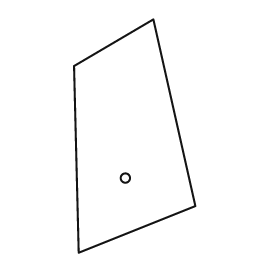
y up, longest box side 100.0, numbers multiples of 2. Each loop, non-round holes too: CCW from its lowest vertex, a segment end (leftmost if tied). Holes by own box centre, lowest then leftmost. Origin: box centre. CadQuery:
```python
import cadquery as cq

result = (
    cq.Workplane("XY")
    .moveTo(-24.0, -50.0)
    .lineTo(26.0, -30.0)
    .lineTo(8.0, 50.0)
    .lineTo(-26.0, 30.0)
    .close()
    .moveTo(-4.0, -18.0)
    .circle(2.0)
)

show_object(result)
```